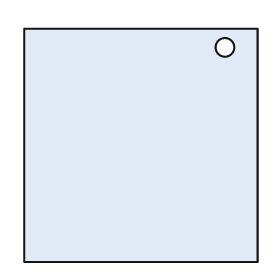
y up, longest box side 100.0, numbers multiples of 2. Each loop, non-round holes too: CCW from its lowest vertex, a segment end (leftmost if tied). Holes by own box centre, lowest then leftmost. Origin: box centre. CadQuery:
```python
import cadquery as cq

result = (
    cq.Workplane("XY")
    .moveTo(-50.0, -50.0)
    .lineTo(50.0, -50.0)
    .lineTo(50.0, 50.0)
    .lineTo(-50.0, 50.0)
    .close()
    .moveTo(36.0, 42.0)
    .circle(4.0)
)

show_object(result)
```